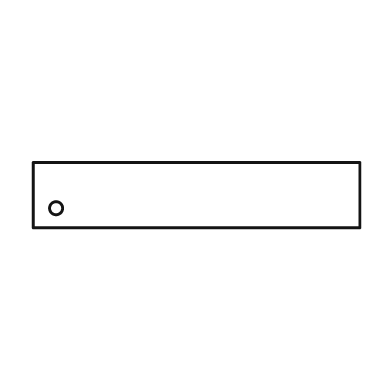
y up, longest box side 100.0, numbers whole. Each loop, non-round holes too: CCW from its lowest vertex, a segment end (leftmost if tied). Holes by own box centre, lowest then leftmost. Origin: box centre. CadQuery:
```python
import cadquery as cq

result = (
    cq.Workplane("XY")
    .moveTo(-50.0, -10.0)
    .lineTo(50.0, -10.0)
    .lineTo(50.0, 10.0)
    .lineTo(-50.0, 10.0)
    .close()
    .moveTo(-43.0, -4.0)
    .circle(2.0)
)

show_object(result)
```